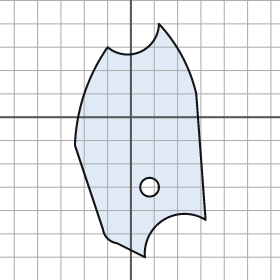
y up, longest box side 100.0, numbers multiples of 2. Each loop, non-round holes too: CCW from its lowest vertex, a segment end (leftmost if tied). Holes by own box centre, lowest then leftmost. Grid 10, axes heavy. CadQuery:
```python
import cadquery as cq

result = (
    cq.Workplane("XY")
    .moveTo(6.0, -60.0)
    .threePointArc((14.0, -44.0), (32.0, -44.0))
    .lineTo(28.0, 10.0)
    .threePointArc((22.0, 26.0), (12.0, 40.0))
    .threePointArc((4.0, 28.0), (-10.0, 30.0))
    .threePointArc((-20.0, 10.0), (-24.0, -12.0))
    .lineTo(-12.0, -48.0)
    .threePointArc((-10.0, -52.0), (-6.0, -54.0))
    .close()
    .moveTo(8.0, -30.0)
    .circle(4.0)
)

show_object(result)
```